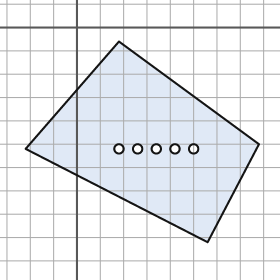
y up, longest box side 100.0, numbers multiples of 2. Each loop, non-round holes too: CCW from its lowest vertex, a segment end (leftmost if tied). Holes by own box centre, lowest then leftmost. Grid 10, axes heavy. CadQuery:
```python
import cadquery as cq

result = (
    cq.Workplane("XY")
    .moveTo(56.0, -92.0)
    .lineTo(78.0, -50.0)
    .lineTo(18.0, -6.0)
    .lineTo(-22.0, -52.0)
    .close()
    .moveTo(18.0, -52.0)
    .circle(2.0)
    .moveTo(26.0, -52.0)
    .circle(2.0)
    .moveTo(34.0, -52.0)
    .circle(2.0)
    .moveTo(42.0, -52.0)
    .circle(2.0)
    .moveTo(50.0, -52.0)
    .circle(2.0)
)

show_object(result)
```